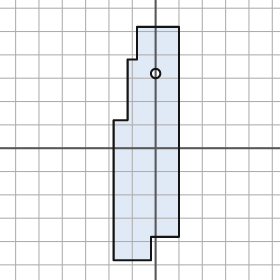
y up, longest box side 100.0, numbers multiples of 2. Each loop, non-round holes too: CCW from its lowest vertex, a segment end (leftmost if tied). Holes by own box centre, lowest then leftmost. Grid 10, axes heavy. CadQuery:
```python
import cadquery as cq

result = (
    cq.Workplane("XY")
    .moveTo(-18.0, -48.0)
    .lineTo(-2.0, -48.0)
    .lineTo(-2.0, -38.0)
    .lineTo(10.0, -38.0)
    .lineTo(10.0, 52.0)
    .lineTo(-8.0, 52.0)
    .lineTo(-8.0, 38.0)
    .lineTo(-12.0, 38.0)
    .lineTo(-12.0, 12.0)
    .lineTo(-18.0, 12.0)
    .close()
    .moveTo(0.0, 32.0)
    .circle(2.0)
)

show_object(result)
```